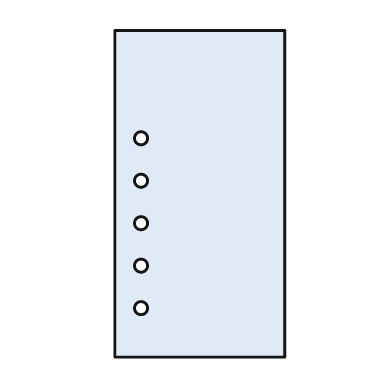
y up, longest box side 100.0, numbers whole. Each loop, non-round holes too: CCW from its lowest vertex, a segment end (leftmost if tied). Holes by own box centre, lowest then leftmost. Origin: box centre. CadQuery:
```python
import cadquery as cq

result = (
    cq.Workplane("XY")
    .moveTo(-26.0, -50.0)
    .lineTo(26.0, -50.0)
    .lineTo(26.0, 50.0)
    .lineTo(-26.0, 50.0)
    .close()
    .moveTo(-18.0, -35.0)
    .circle(2.0)
    .moveTo(-18.0, -22.0)
    .circle(2.0)
    .moveTo(-18.0, -9.0)
    .circle(2.0)
    .moveTo(-18.0, 4.0)
    .circle(2.0)
    .moveTo(-18.0, 17.0)
    .circle(2.0)
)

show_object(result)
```